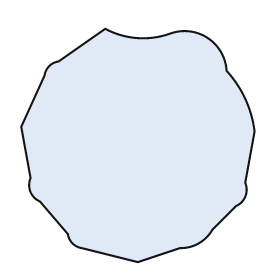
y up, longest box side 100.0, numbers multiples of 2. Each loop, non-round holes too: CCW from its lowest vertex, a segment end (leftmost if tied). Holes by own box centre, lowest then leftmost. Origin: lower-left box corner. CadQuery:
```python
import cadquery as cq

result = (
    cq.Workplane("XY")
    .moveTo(50.0, 0.0)
    .lineTo(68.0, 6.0)
    .threePointArc((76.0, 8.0), (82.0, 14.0))
    .lineTo(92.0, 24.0)
    .threePointArc((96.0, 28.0), (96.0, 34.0))
    .lineTo(100.0, 56.0)
    .threePointArc((96.0, 70.0), (88.0, 82.0))
    .threePointArc((80.0, 96.0), (64.0, 98.0))
    .threePointArc((50.0, 96.0), (36.0, 100.0))
    .lineTo(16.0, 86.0)
    .threePointArc((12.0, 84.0), (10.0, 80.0))
    .lineTo(0.0, 58.0)
    .lineTo(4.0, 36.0)
    .threePointArc((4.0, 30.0), (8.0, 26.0))
    .lineTo(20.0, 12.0)
    .threePointArc((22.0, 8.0), (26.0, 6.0))
    .close()
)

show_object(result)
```